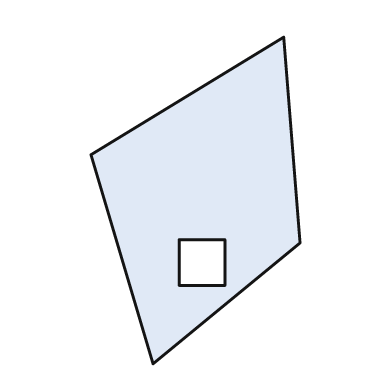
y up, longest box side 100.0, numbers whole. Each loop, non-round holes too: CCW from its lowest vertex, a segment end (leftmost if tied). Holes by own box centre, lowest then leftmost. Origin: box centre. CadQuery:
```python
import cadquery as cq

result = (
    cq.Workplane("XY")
    .moveTo(-13.0, -50.0)
    .lineTo(32.0, -13.0)
    .lineTo(27.0, 50.0)
    .lineTo(-32.0, 14.0)
    .close()
    .moveTo(-5.0, -26.0)
    .lineTo(9.0, -26.0)
    .lineTo(9.0, -12.0)
    .lineTo(-5.0, -12.0)
    .close()
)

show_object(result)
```